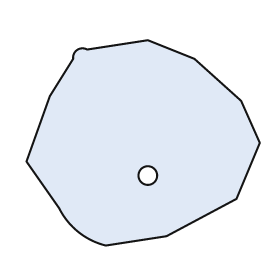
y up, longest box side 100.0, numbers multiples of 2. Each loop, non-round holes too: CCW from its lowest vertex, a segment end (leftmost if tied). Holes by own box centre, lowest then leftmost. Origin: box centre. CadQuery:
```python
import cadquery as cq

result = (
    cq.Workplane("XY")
    .moveTo(-16.0, -44.0)
    .lineTo(10.0, -40.0)
    .lineTo(40.0, -24.0)
    .lineTo(50.0, 0.0)
    .lineTo(42.0, 18.0)
    .lineTo(22.0, 36.0)
    .lineTo(2.0, 44.0)
    .lineTo(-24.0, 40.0)
    .threePointArc((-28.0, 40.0), (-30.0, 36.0))
    .lineTo(-40.0, 20.0)
    .lineTo(-50.0, -8.0)
    .lineTo(-36.0, -28.0)
    .threePointArc((-28.0, -38.0), (-16.0, -44.0))
    .close()
    .moveTo(2.0, -14.0)
    .circle(4.0)
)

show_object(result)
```